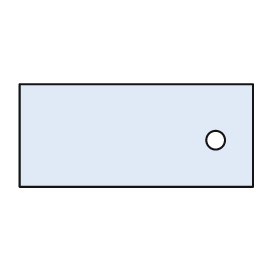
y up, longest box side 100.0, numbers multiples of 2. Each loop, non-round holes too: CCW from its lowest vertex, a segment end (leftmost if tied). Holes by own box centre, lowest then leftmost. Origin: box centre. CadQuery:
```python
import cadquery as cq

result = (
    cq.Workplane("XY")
    .moveTo(-50.0, -22.0)
    .lineTo(50.0, -22.0)
    .lineTo(50.0, 22.0)
    .lineTo(-50.0, 22.0)
    .close()
    .moveTo(34.0, -2.0)
    .circle(4.0)
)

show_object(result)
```